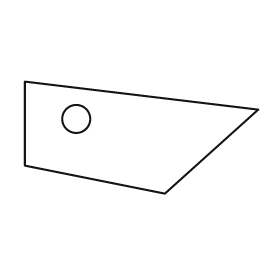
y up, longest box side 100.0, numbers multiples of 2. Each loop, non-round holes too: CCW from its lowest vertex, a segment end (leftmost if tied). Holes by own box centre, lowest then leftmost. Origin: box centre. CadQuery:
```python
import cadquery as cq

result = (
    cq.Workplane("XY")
    .moveTo(10.0, -24.0)
    .lineTo(50.0, 12.0)
    .lineTo(-50.0, 24.0)
    .lineTo(-50.0, -12.0)
    .close()
    .moveTo(-28.0, 8.0)
    .circle(6.0)
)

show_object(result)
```